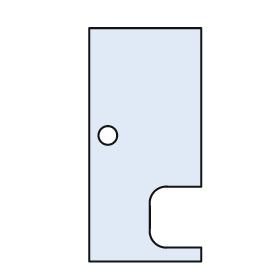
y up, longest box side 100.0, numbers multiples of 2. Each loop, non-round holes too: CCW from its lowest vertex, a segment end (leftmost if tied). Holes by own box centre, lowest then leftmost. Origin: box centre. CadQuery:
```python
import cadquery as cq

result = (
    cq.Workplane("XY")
    .moveTo(-24.0, -50.0)
    .lineTo(24.0, -50.0)
    .lineTo(24.0, -44.0)
    .lineTo(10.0, -44.0)
    .threePointArc((4.0, -42.0), (2.0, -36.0))
    .lineTo(2.0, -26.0)
    .threePointArc((4.0, -20.0), (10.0, -18.0))
    .lineTo(24.0, -18.0)
    .lineTo(24.0, 50.0)
    .lineTo(-24.0, 50.0)
    .close()
    .moveTo(-16.0, 4.0)
    .circle(4.0)
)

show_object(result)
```